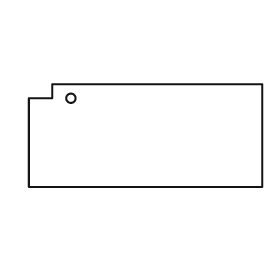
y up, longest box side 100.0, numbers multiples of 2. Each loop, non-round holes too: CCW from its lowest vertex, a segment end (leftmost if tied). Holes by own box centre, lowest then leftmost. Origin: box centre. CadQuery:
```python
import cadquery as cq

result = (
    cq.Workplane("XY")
    .moveTo(-50.0, -22.0)
    .lineTo(50.0, -22.0)
    .lineTo(50.0, 22.0)
    .lineTo(-40.0, 22.0)
    .lineTo(-40.0, 16.0)
    .lineTo(-50.0, 16.0)
    .close()
    .moveTo(-32.0, 16.0)
    .circle(2.0)
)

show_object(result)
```